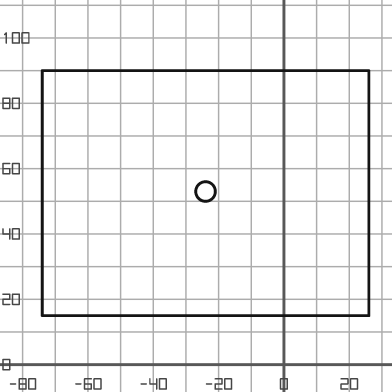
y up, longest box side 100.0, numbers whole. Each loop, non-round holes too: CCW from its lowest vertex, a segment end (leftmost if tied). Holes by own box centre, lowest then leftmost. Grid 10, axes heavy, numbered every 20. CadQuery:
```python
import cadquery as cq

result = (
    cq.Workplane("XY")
    .moveTo(-74.0, 15.0)
    .lineTo(26.0, 15.0)
    .lineTo(26.0, 90.0)
    .lineTo(-74.0, 90.0)
    .close()
    .moveTo(-24.0, 53.0)
    .circle(3.0)
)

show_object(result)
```